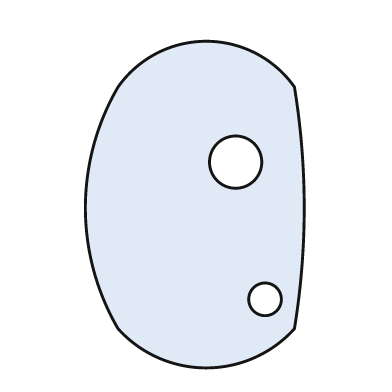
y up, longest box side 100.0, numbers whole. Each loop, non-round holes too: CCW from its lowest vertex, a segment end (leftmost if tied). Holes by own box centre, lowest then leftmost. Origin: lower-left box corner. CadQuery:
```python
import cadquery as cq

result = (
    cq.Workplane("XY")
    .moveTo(10.0, 12.0)
    .threePointArc((37.0, 0.0), (64.0, 12.0))
    .threePointArc((67.0, 49.0), (64.0, 86.0))
    .threePointArc((37.0, 100.0), (10.0, 86.0))
    .threePointArc((0.0, 49.0), (10.0, 12.0))
    .close()
    .moveTo(55.0, 21.0)
    .circle(5.0)
    .moveTo(46.0, 63.0)
    .circle(8.0)
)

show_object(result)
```